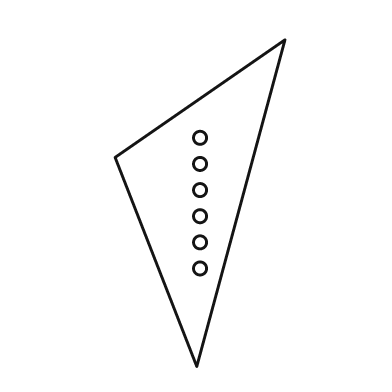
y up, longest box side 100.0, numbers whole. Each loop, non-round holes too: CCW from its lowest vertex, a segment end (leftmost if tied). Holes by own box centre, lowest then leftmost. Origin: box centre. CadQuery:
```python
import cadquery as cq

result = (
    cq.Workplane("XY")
    .moveTo(-1.0, -50.0)
    .lineTo(26.0, 50.0)
    .lineTo(-26.0, 14.0)
    .close()
    .moveTo(0.0, -20.0)
    .circle(2.0)
    .moveTo(0.0, -12.0)
    .circle(2.0)
    .moveTo(0.0, -4.0)
    .circle(2.0)
    .moveTo(0.0, 4.0)
    .circle(2.0)
    .moveTo(0.0, 12.0)
    .circle(2.0)
    .moveTo(0.0, 20.0)
    .circle(2.0)
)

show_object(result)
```